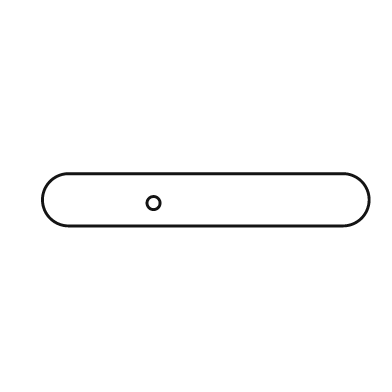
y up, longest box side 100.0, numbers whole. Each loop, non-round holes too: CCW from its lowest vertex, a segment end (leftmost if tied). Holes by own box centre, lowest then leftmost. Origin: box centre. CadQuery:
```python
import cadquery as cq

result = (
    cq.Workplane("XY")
    .moveTo(-42.0, -8.0)
    .lineTo(42.0, -8.0)
    .threePointArc((50.0, 0.0), (42.0, 8.0))
    .lineTo(-42.0, 8.0)
    .threePointArc((-50.0, 0.0), (-42.0, -8.0))
    .close()
    .moveTo(-16.0, -1.0)
    .circle(2.0)
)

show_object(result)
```